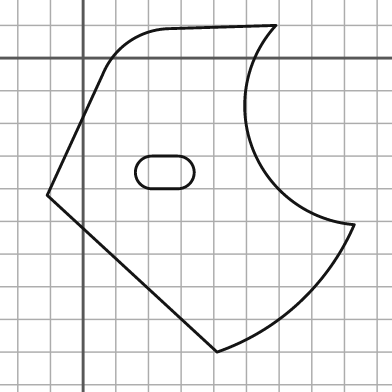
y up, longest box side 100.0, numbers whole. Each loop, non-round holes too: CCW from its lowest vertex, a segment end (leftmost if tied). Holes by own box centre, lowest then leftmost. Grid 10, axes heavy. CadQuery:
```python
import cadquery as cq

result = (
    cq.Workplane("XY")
    .moveTo(41.0, -90.0)
    .threePointArc((66.0, -75.0), (83.0, -51.0))
    .threePointArc((52.0, -28.0), (59.0, 10.0))
    .lineTo(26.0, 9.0)
    .threePointArc((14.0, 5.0), (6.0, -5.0))
    .lineTo(-11.0, -42.0)
    .close()
    .moveTo(21.0, -40.0)
    .lineTo(29.0, -40.0)
    .threePointArc((34.0, -35.0), (29.0, -30.0))
    .lineTo(21.0, -30.0)
    .threePointArc((16.0, -35.0), (21.0, -40.0))
    .close()
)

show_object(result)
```